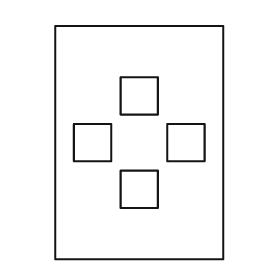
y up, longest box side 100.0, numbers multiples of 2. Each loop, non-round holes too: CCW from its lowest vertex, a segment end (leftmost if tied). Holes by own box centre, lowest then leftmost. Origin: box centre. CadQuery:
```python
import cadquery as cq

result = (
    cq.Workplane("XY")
    .moveTo(-36.0, -50.0)
    .lineTo(36.0, -50.0)
    .lineTo(36.0, 50.0)
    .lineTo(-36.0, 50.0)
    .close()
    .moveTo(-8.0, -28.0)
    .lineTo(8.0, -28.0)
    .lineTo(8.0, -12.0)
    .lineTo(-8.0, -12.0)
    .close()
    .moveTo(-28.0, -8.0)
    .lineTo(-12.0, -8.0)
    .lineTo(-12.0, 8.0)
    .lineTo(-28.0, 8.0)
    .close()
    .moveTo(12.0, -8.0)
    .lineTo(28.0, -8.0)
    .lineTo(28.0, 8.0)
    .lineTo(12.0, 8.0)
    .close()
    .moveTo(-8.0, 12.0)
    .lineTo(8.0, 12.0)
    .lineTo(8.0, 28.0)
    .lineTo(-8.0, 28.0)
    .close()
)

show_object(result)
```